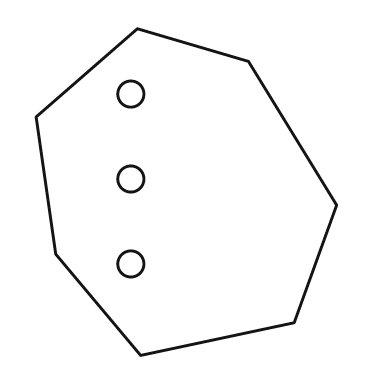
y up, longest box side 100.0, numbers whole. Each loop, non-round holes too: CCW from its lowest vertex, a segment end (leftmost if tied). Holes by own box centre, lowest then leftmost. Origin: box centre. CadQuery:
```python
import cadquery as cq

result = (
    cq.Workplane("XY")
    .moveTo(-14.0, -50.0)
    .lineTo(33.0, -40.0)
    .lineTo(46.0, -4.0)
    .lineTo(19.0, 40.0)
    .lineTo(-15.0, 50.0)
    .lineTo(-46.0, 23.0)
    .lineTo(-40.0, -19.0)
    .close()
    .moveTo(-17.0, -22.0)
    .circle(4.0)
    .moveTo(-17.0, 4.0)
    .circle(4.0)
    .moveTo(-17.0, 30.0)
    .circle(4.0)
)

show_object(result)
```